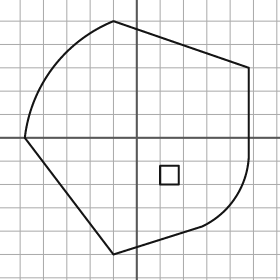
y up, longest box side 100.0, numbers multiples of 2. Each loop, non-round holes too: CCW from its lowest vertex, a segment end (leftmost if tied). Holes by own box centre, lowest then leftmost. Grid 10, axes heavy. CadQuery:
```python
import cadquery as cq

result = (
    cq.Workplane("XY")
    .moveTo(-10.0, -50.0)
    .lineTo(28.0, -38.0)
    .threePointArc((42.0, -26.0), (48.0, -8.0))
    .lineTo(48.0, 30.0)
    .lineTo(-10.0, 50.0)
    .threePointArc((-36.0, 30.0), (-48.0, 0.0))
    .close()
    .moveTo(10.0, -20.0)
    .lineTo(18.0, -20.0)
    .lineTo(18.0, -12.0)
    .lineTo(10.0, -12.0)
    .close()
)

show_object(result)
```